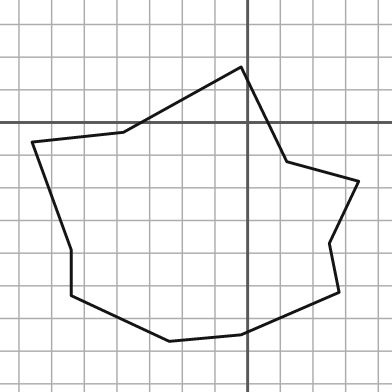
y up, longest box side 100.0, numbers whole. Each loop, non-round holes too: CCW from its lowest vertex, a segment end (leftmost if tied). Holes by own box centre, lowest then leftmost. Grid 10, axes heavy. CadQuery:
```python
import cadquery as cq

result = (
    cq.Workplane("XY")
    .moveTo(-24.0, -67.0)
    .lineTo(-2.0, -65.0)
    .lineTo(28.0, -52.0)
    .lineTo(25.0, -37.0)
    .lineTo(34.0, -18.0)
    .lineTo(12.0, -12.0)
    .lineTo(-2.0, 17.0)
    .lineTo(-38.0, -3.0)
    .lineTo(-66.0, -6.0)
    .lineTo(-54.0, -39.0)
    .lineTo(-54.0, -53.0)
    .close()
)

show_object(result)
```